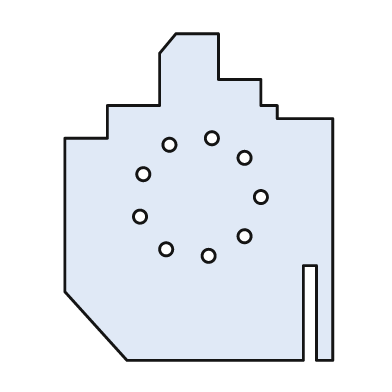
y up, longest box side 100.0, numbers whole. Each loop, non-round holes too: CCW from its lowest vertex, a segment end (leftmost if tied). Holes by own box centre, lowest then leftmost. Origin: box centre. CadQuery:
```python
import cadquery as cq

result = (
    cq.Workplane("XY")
    .moveTo(-22.0, -50.0)
    .lineTo(32.0, -50.0)
    .lineTo(32.0, -21.0)
    .lineTo(36.0, -21.0)
    .lineTo(36.0, -50.0)
    .lineTo(41.0, -50.0)
    .lineTo(41.0, 24.0)
    .lineTo(24.0, 24.0)
    .lineTo(24.0, 28.0)
    .lineTo(19.0, 28.0)
    .lineTo(19.0, 36.0)
    .lineTo(6.0, 36.0)
    .lineTo(6.0, 50.0)
    .lineTo(-7.0, 50.0)
    .lineTo(-12.0, 44.0)
    .lineTo(-12.0, 28.0)
    .lineTo(-28.0, 28.0)
    .lineTo(-28.0, 18.0)
    .lineTo(-41.0, 18.0)
    .lineTo(-41.0, -29.0)
    .close()
    .moveTo(3.0, -18.0)
    .circle(2.0)
    .moveTo(-10.0, -16.0)
    .circle(2.0)
    .moveTo(14.0, -12.0)
    .circle(2.0)
    .moveTo(-18.0, -6.0)
    .circle(2.0)
    .moveTo(19.0, 0.0)
    .circle(2.0)
    .moveTo(-17.0, 7.0)
    .circle(2.0)
    .moveTo(14.0, 12.0)
    .circle(2.0)
    .moveTo(-9.0, 16.0)
    .circle(2.0)
    .moveTo(4.0, 18.0)
    .circle(2.0)
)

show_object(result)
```